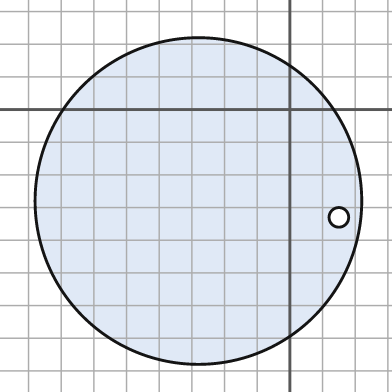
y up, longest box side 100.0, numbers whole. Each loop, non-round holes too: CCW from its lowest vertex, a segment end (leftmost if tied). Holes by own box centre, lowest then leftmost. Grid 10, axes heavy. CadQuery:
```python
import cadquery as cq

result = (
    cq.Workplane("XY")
    .moveTo(-28.0, -28.0)
    .circle(50.0)
    .moveTo(15.0, -33.0)
    .circle(3.0)
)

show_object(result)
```